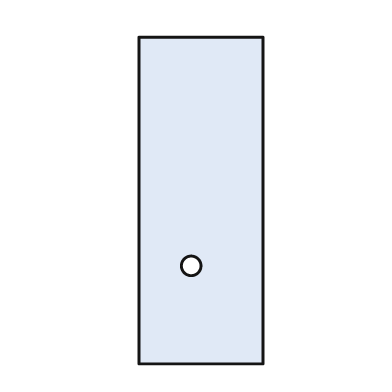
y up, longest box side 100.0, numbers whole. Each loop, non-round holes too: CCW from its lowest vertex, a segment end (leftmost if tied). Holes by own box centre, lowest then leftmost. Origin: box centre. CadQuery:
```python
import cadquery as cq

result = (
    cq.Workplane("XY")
    .moveTo(-19.0, -50.0)
    .lineTo(19.0, -50.0)
    .lineTo(19.0, 50.0)
    .lineTo(-19.0, 50.0)
    .close()
    .moveTo(-3.0, -20.0)
    .circle(3.0)
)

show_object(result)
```